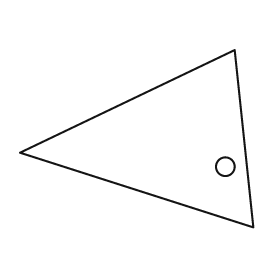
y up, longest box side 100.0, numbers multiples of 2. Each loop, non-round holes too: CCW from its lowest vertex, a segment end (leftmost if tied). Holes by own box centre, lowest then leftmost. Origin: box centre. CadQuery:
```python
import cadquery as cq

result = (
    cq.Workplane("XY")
    .moveTo(50.0, -38.0)
    .lineTo(42.0, 38.0)
    .lineTo(-50.0, -6.0)
    .close()
    .moveTo(38.0, -12.0)
    .circle(4.0)
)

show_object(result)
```